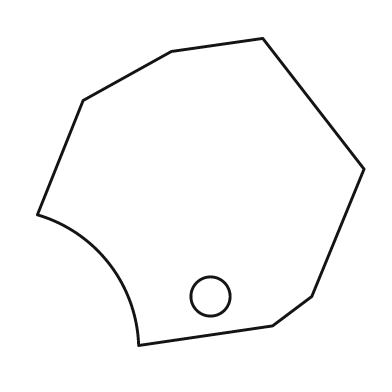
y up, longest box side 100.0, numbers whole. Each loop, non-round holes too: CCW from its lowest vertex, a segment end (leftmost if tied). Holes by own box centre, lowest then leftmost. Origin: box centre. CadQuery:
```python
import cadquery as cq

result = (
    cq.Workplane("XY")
    .moveTo(-19.0, -47.0)
    .lineTo(22.0, -41.0)
    .lineTo(34.0, -32.0)
    .lineTo(50.0, 7.0)
    .lineTo(19.0, 47.0)
    .lineTo(-9.0, 43.0)
    .lineTo(-36.0, 28.0)
    .lineTo(-50.0, -7.0)
    .threePointArc((-28.0, -22.0), (-19.0, -47.0))
    .close()
    .moveTo(3.0, -32.0)
    .circle(6.0)
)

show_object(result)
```